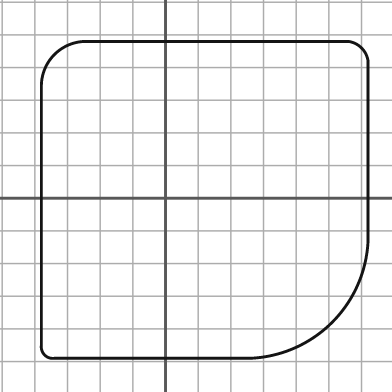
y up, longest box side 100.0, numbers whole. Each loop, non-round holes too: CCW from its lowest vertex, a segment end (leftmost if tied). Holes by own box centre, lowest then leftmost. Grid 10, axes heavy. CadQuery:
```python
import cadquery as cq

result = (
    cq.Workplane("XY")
    .moveTo(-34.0, -49.0)
    .lineTo(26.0, -49.0)
    .threePointArc((51.0, -38.0), (62.0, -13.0))
    .lineTo(62.0, 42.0)
    .threePointArc((60.0, 46.0), (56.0, 48.0))
    .lineTo(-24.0, 48.0)
    .threePointArc((-34.0, 44.0), (-38.0, 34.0))
    .lineTo(-38.0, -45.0)
    .threePointArc((-37.0, -48.0), (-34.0, -49.0))
    .close()
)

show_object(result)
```